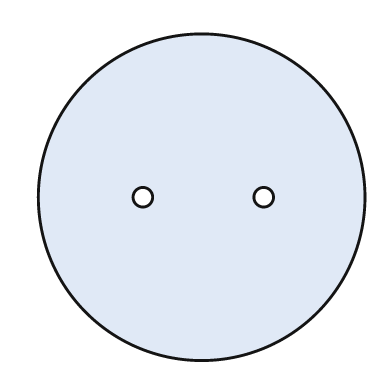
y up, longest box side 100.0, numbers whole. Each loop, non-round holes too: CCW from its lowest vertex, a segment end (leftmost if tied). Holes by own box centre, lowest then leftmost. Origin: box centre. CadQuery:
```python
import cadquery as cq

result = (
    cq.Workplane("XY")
    .moveTo(0.0, 0.0)
    .circle(50.0)
    .moveTo(-18.0, 0.0)
    .circle(3.0)
    .moveTo(19.0, 0.0)
    .circle(3.0)
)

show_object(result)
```